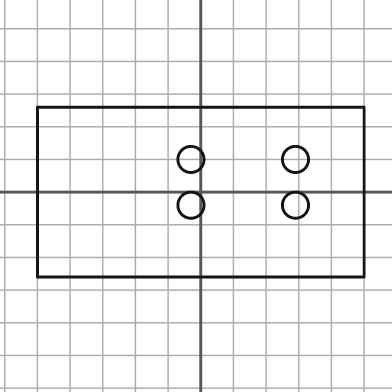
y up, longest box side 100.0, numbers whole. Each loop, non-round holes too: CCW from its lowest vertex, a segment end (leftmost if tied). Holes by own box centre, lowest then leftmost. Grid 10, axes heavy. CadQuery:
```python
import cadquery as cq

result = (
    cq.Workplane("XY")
    .moveTo(-50.0, -26.0)
    .lineTo(50.0, -26.0)
    .lineTo(50.0, 26.0)
    .lineTo(-50.0, 26.0)
    .close()
    .moveTo(-3.0, -4.0)
    .circle(4.0)
    .moveTo(29.0, -4.0)
    .circle(4.0)
    .moveTo(-3.0, 10.0)
    .circle(4.0)
    .moveTo(29.0, 10.0)
    .circle(4.0)
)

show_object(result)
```